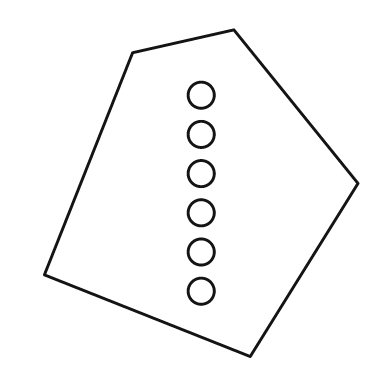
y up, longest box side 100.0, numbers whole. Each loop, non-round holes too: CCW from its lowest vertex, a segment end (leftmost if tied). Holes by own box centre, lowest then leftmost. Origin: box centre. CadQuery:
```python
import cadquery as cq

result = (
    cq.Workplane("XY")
    .moveTo(15.0, -50.0)
    .lineTo(48.0, 3.0)
    .lineTo(10.0, 50.0)
    .lineTo(-21.0, 43.0)
    .lineTo(-48.0, -25.0)
    .close()
    .moveTo(0.0, -30.0)
    .circle(4.0)
    .moveTo(0.0, -18.0)
    .circle(4.0)
    .moveTo(0.0, -6.0)
    .circle(4.0)
    .moveTo(0.0, 6.0)
    .circle(4.0)
    .moveTo(0.0, 18.0)
    .circle(4.0)
    .moveTo(0.0, 30.0)
    .circle(4.0)
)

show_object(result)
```